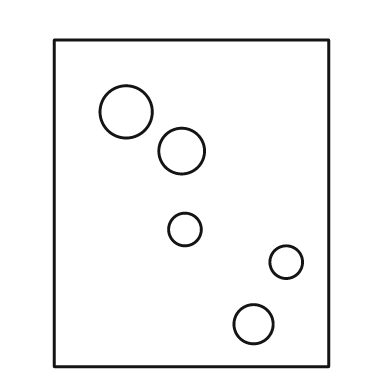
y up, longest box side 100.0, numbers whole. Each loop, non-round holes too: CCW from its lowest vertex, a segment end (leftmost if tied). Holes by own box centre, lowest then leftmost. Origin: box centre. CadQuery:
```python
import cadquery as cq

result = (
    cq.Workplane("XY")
    .moveTo(-42.0, -50.0)
    .lineTo(42.0, -50.0)
    .lineTo(42.0, 50.0)
    .lineTo(-42.0, 50.0)
    .close()
    .moveTo(19.0, -37.0)
    .circle(6.0)
    .moveTo(29.0, -18.0)
    .circle(5.0)
    .moveTo(-2.0, -8.0)
    .circle(5.0)
    .moveTo(-3.0, 16.0)
    .circle(7.0)
    .moveTo(-20.0, 28.0)
    .circle(8.0)
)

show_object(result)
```